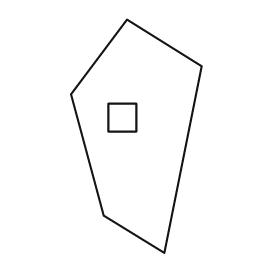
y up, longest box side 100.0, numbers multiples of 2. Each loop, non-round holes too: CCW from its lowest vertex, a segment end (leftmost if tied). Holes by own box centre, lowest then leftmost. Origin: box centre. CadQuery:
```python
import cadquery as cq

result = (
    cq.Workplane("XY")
    .moveTo(12.0, -50.0)
    .lineTo(28.0, 30.0)
    .lineTo(-4.0, 50.0)
    .lineTo(-28.0, 18.0)
    .lineTo(-14.0, -34.0)
    .close()
    .moveTo(-12.0, 2.0)
    .lineTo(0.0, 2.0)
    .lineTo(0.0, 14.0)
    .lineTo(-12.0, 14.0)
    .close()
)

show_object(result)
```